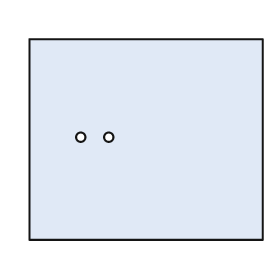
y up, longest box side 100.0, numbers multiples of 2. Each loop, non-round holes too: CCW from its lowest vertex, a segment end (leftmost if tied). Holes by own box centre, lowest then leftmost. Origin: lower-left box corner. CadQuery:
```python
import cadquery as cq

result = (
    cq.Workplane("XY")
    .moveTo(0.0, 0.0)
    .lineTo(100.0, 0.0)
    .lineTo(100.0, 86.0)
    .lineTo(0.0, 86.0)
    .close()
    .moveTo(22.0, 44.0)
    .circle(2.0)
    .moveTo(34.0, 44.0)
    .circle(2.0)
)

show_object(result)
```